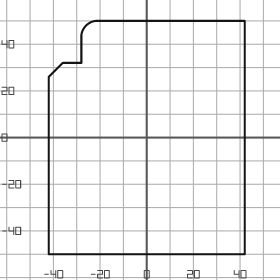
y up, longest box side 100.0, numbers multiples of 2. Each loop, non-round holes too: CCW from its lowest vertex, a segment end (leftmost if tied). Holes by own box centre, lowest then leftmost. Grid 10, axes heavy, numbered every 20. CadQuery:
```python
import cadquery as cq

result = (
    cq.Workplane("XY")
    .moveTo(-42.0, -50.0)
    .lineTo(42.0, -50.0)
    .lineTo(42.0, 50.0)
    .lineTo(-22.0, 50.0)
    .threePointArc((-26.0, 48.0), (-28.0, 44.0))
    .lineTo(-28.0, 32.0)
    .lineTo(-36.0, 32.0)
    .lineTo(-42.0, 26.0)
    .close()
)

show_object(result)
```